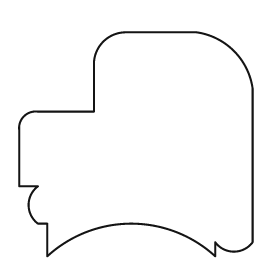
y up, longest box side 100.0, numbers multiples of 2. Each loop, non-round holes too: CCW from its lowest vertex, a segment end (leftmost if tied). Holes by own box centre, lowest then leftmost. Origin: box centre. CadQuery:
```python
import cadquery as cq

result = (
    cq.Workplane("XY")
    .moveTo(-38.0, -48.0)
    .threePointArc((-2.0, -34.0), (34.0, -48.0))
    .lineTo(34.0, -42.0)
    .threePointArc((42.0, -46.0), (50.0, -42.0))
    .lineTo(50.0, 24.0)
    .threePointArc((42.0, 40.0), (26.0, 48.0))
    .lineTo(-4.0, 48.0)
    .threePointArc((-14.0, 44.0), (-18.0, 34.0))
    .lineTo(-18.0, 14.0)
    .lineTo(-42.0, 14.0)
    .threePointArc((-48.0, 12.0), (-50.0, 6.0))
    .lineTo(-50.0, -18.0)
    .lineTo(-42.0, -18.0)
    .threePointArc((-46.0, -26.0), (-42.0, -34.0))
    .lineTo(-38.0, -34.0)
    .close()
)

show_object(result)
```